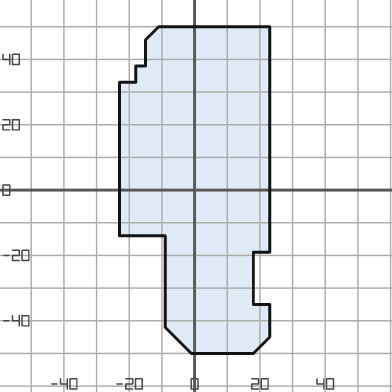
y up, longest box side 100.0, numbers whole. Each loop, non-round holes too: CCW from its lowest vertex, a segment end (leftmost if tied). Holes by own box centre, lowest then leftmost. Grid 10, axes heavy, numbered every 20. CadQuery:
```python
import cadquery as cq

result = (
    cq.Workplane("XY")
    .moveTo(-1.0, -50.0)
    .lineTo(18.0, -50.0)
    .lineTo(23.0, -45.0)
    .lineTo(23.0, -35.0)
    .lineTo(18.0, -35.0)
    .lineTo(18.0, -19.0)
    .lineTo(23.0, -19.0)
    .lineTo(23.0, 50.0)
    .lineTo(-11.0, 50.0)
    .lineTo(-15.0, 46.0)
    .lineTo(-15.0, 38.0)
    .lineTo(-18.0, 38.0)
    .lineTo(-18.0, 33.0)
    .lineTo(-23.0, 33.0)
    .lineTo(-23.0, -14.0)
    .lineTo(-9.0, -14.0)
    .lineTo(-9.0, -42.0)
    .close()
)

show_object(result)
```